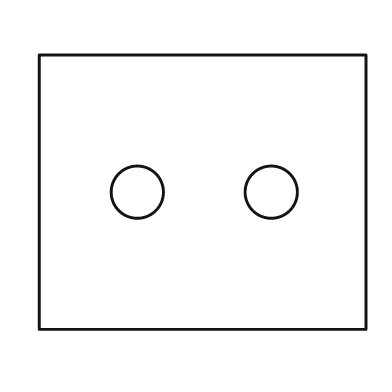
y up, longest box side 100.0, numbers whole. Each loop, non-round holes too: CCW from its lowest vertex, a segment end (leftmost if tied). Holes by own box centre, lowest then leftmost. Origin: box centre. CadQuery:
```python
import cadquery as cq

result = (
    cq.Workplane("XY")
    .moveTo(-50.0, -42.0)
    .lineTo(50.0, -42.0)
    .lineTo(50.0, 42.0)
    .lineTo(-50.0, 42.0)
    .close()
    .moveTo(-20.0, 0.0)
    .circle(8.0)
    .moveTo(21.0, 0.0)
    .circle(8.0)
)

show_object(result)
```